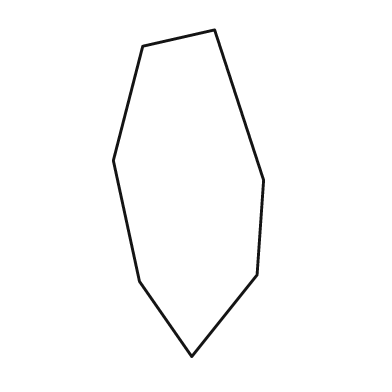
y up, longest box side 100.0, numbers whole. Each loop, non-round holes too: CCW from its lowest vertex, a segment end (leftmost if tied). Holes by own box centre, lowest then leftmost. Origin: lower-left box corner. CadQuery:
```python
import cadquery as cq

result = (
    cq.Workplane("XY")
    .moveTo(24.0, 0.0)
    .lineTo(44.0, 25.0)
    .lineTo(46.0, 54.0)
    .lineTo(31.0, 100.0)
    .lineTo(9.0, 95.0)
    .lineTo(0.0, 60.0)
    .lineTo(8.0, 23.0)
    .close()
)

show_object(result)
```